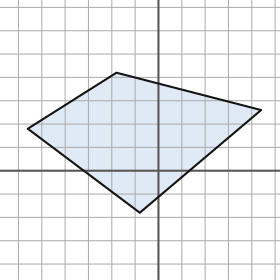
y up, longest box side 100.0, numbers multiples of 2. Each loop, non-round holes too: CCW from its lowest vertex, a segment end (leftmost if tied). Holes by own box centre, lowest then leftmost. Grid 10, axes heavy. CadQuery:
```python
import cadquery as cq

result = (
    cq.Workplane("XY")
    .moveTo(-8.0, -18.0)
    .lineTo(44.0, 26.0)
    .lineTo(-18.0, 42.0)
    .lineTo(-56.0, 18.0)
    .close()
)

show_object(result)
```